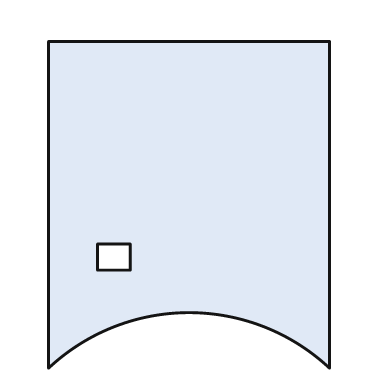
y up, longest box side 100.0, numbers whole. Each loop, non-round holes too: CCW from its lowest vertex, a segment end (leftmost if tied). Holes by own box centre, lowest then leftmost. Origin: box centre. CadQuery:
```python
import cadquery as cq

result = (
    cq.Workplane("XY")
    .moveTo(-43.0, -50.0)
    .threePointArc((0.0, -33.0), (43.0, -50.0))
    .lineTo(43.0, 50.0)
    .lineTo(-43.0, 50.0)
    .close()
    .moveTo(-28.0, -20.0)
    .lineTo(-18.0, -20.0)
    .lineTo(-18.0, -12.0)
    .lineTo(-28.0, -12.0)
    .close()
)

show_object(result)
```